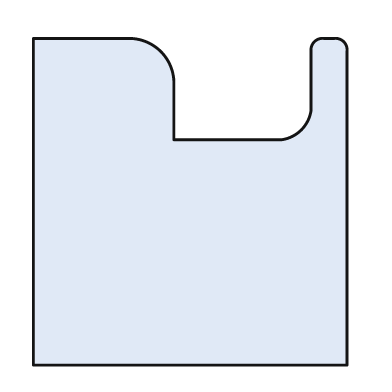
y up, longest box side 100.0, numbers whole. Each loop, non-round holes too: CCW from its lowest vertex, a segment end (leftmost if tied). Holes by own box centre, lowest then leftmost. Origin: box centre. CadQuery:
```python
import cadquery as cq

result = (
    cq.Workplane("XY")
    .moveTo(-48.0, -50.0)
    .lineTo(48.0, -50.0)
    .lineTo(48.0, 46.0)
    .threePointArc((47.0, 49.0), (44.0, 50.0))
    .lineTo(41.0, 50.0)
    .threePointArc((38.0, 49.0), (37.0, 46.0))
    .lineTo(37.0, 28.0)
    .threePointArc((34.0, 22.0), (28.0, 19.0))
    .lineTo(-5.0, 19.0)
    .lineTo(-5.0, 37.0)
    .threePointArc((-9.0, 46.0), (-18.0, 50.0))
    .lineTo(-48.0, 50.0)
    .close()
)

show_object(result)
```